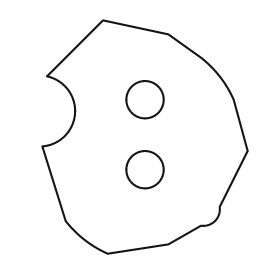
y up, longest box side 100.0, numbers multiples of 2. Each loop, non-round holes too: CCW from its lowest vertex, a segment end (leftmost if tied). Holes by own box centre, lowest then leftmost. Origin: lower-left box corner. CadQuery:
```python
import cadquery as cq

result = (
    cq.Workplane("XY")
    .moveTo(28.0, 0.0)
    .lineTo(54.0, 4.0)
    .lineTo(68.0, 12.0)
    .threePointArc((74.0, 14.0), (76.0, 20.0))
    .lineTo(88.0, 44.0)
    .lineTo(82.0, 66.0)
    .threePointArc((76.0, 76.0), (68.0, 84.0))
    .lineTo(54.0, 94.0)
    .lineTo(26.0, 100.0)
    .lineTo(2.0, 76.0)
    .threePointArc((14.0, 60.0), (0.0, 46.0))
    .lineTo(10.0, 14.0)
    .threePointArc((18.0, 6.0), (28.0, 0.0))
    .close()
    .moveTo(44.0, 36.0)
    .circle(8.0)
    .moveTo(44.0, 66.0)
    .circle(8.0)
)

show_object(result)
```